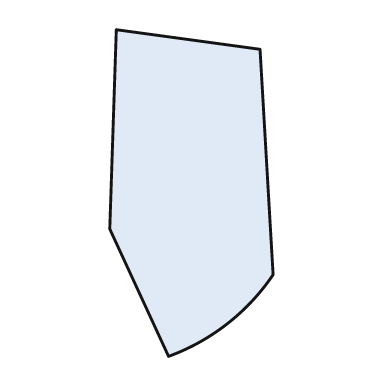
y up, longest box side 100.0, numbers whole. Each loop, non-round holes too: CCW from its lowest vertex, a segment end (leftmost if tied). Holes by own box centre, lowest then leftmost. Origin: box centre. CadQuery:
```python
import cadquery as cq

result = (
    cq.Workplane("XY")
    .moveTo(-7.0, -50.0)
    .threePointArc((11.0, -40.0), (25.0, -25.0))
    .lineTo(21.0, 44.0)
    .lineTo(-23.0, 50.0)
    .lineTo(-25.0, -11.0)
    .close()
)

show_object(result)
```